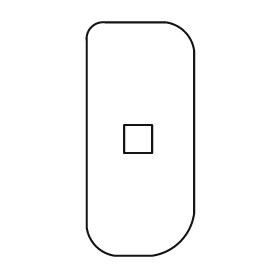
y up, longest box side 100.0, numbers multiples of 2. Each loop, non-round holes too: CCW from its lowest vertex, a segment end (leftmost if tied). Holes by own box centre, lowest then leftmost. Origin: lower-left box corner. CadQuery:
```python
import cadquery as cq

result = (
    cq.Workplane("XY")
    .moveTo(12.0, 0.0)
    .lineTo(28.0, 0.0)
    .threePointArc((40.0, 6.0), (46.0, 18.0))
    .lineTo(46.0, 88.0)
    .threePointArc((42.0, 96.0), (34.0, 100.0))
    .lineTo(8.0, 100.0)
    .threePointArc((2.0, 98.0), (0.0, 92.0))
    .lineTo(0.0, 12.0)
    .threePointArc((4.0, 4.0), (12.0, 0.0))
    .close()
    .moveTo(16.0, 44.0)
    .lineTo(28.0, 44.0)
    .lineTo(28.0, 56.0)
    .lineTo(16.0, 56.0)
    .close()
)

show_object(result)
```